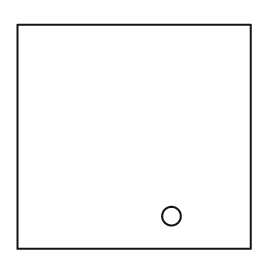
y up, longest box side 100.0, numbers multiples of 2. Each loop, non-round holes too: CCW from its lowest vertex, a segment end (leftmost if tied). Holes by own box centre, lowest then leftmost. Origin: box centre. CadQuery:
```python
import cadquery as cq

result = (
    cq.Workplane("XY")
    .moveTo(-50.0, -48.0)
    .lineTo(50.0, -48.0)
    .lineTo(50.0, 48.0)
    .lineTo(-50.0, 48.0)
    .close()
    .moveTo(16.0, -34.0)
    .circle(4.0)
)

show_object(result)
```